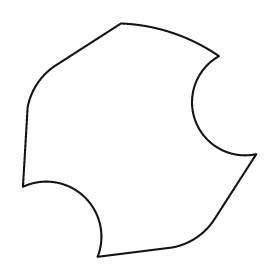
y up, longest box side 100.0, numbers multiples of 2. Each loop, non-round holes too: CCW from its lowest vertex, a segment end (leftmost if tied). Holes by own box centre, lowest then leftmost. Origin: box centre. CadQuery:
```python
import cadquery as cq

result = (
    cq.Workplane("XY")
    .moveTo(-18.0, -50.0)
    .lineTo(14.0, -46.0)
    .threePointArc((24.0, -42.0), (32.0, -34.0))
    .lineTo(50.0, -6.0)
    .threePointArc((24.0, 8.0), (34.0, 36.0))
    .threePointArc((14.0, 46.0), (-8.0, 50.0))
    .lineTo(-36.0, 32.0)
    .threePointArc((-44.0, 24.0), (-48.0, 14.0))
    .lineTo(-50.0, -20.0)
    .threePointArc((-24.0, -24.0), (-18.0, -50.0))
    .close()
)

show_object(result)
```